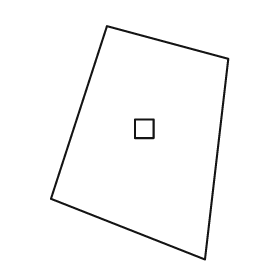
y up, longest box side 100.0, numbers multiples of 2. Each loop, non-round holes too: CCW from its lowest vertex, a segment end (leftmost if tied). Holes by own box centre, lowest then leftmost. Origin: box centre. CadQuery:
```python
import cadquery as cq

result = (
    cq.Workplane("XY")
    .moveTo(28.0, -50.0)
    .lineTo(38.0, 36.0)
    .lineTo(-14.0, 50.0)
    .lineTo(-38.0, -24.0)
    .close()
    .moveTo(-2.0, 2.0)
    .lineTo(6.0, 2.0)
    .lineTo(6.0, 10.0)
    .lineTo(-2.0, 10.0)
    .close()
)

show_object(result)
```